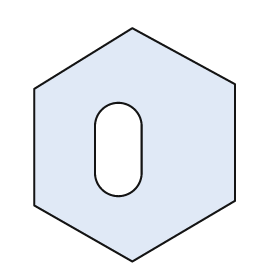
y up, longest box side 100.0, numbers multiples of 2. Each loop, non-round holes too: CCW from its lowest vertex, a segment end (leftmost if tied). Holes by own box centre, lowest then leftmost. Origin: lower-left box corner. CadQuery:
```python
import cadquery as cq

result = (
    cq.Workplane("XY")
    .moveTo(42.0, 0.0)
    .lineTo(86.0, 26.0)
    .lineTo(86.0, 76.0)
    .lineTo(42.0, 100.0)
    .lineTo(0.0, 74.0)
    .lineTo(0.0, 24.0)
    .close()
    .moveTo(26.0, 38.0)
    .threePointArc((36.0, 28.0), (46.0, 38.0))
    .lineTo(46.0, 58.0)
    .threePointArc((36.0, 68.0), (26.0, 58.0))
    .close()
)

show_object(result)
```